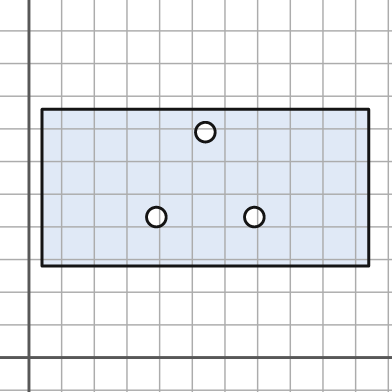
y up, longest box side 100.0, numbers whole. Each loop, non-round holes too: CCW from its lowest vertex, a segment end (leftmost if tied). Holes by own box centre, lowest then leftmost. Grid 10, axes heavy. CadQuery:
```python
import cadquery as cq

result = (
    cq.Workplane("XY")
    .moveTo(4.0, 28.0)
    .lineTo(104.0, 28.0)
    .lineTo(104.0, 76.0)
    .lineTo(4.0, 76.0)
    .close()
    .moveTo(39.0, 43.0)
    .circle(3.0)
    .moveTo(69.0, 43.0)
    .circle(3.0)
    .moveTo(54.0, 69.0)
    .circle(3.0)
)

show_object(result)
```